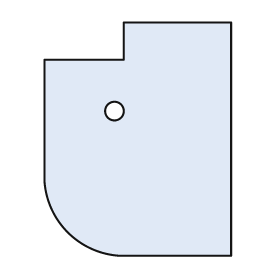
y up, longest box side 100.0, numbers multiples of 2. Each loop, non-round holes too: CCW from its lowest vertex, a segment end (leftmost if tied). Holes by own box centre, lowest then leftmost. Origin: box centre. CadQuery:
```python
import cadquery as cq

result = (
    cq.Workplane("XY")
    .moveTo(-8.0, -50.0)
    .lineTo(40.0, -50.0)
    .lineTo(40.0, 50.0)
    .lineTo(-6.0, 50.0)
    .lineTo(-6.0, 34.0)
    .lineTo(-40.0, 34.0)
    .lineTo(-40.0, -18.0)
    .threePointArc((-30.0, -40.0), (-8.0, -50.0))
    .close()
    .moveTo(-10.0, 12.0)
    .circle(4.0)
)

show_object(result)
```